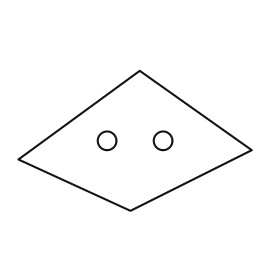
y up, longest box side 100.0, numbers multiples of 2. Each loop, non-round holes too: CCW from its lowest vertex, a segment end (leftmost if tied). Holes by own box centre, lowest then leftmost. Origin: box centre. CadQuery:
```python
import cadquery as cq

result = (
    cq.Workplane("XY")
    .moveTo(-2.0, -30.0)
    .lineTo(50.0, -4.0)
    .lineTo(2.0, 30.0)
    .lineTo(-50.0, -8.0)
    .close()
    .moveTo(-12.0, 0.0)
    .circle(4.0)
    .moveTo(12.0, 0.0)
    .circle(4.0)
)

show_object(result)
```